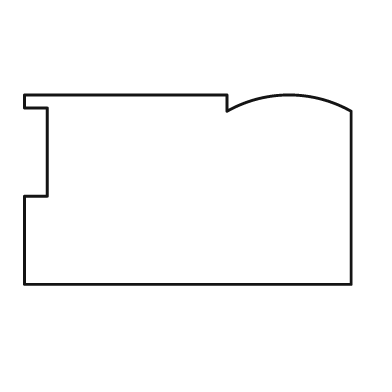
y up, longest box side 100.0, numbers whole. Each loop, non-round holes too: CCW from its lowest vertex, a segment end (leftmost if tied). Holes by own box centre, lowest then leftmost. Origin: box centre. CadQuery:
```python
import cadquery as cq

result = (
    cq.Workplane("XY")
    .moveTo(-50.0, -29.0)
    .lineTo(50.0, -29.0)
    .lineTo(50.0, 24.0)
    .threePointArc((31.0, 29.0), (12.0, 24.0))
    .lineTo(12.0, 29.0)
    .lineTo(-50.0, 29.0)
    .lineTo(-50.0, 25.0)
    .lineTo(-43.0, 25.0)
    .lineTo(-43.0, -2.0)
    .lineTo(-50.0, -2.0)
    .close()
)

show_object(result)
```